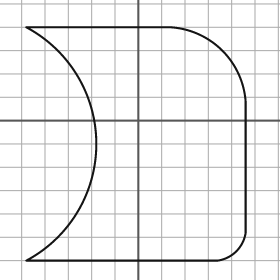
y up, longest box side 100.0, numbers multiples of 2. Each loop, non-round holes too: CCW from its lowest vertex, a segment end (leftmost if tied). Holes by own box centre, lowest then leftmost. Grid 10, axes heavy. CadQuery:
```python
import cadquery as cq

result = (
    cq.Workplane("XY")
    .moveTo(-48.0, -60.0)
    .lineTo(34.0, -60.0)
    .threePointArc((42.0, -56.0), (46.0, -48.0))
    .lineTo(46.0, 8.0)
    .threePointArc((36.0, 30.0), (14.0, 40.0))
    .lineTo(-48.0, 40.0)
    .threePointArc((-18.0, -10.0), (-48.0, -60.0))
    .close()
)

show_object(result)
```